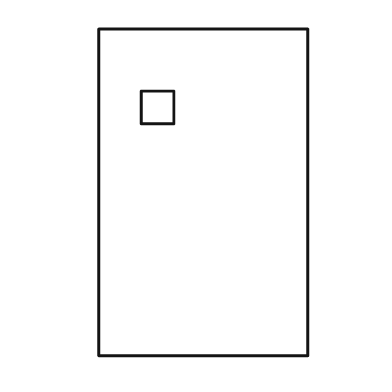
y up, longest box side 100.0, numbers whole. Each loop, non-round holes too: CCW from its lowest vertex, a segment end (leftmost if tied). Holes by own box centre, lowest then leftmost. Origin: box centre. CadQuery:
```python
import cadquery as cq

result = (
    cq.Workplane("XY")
    .moveTo(-32.0, -50.0)
    .lineTo(32.0, -50.0)
    .lineTo(32.0, 50.0)
    .lineTo(-32.0, 50.0)
    .close()
    .moveTo(-19.0, 21.0)
    .lineTo(-9.0, 21.0)
    .lineTo(-9.0, 31.0)
    .lineTo(-19.0, 31.0)
    .close()
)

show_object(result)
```